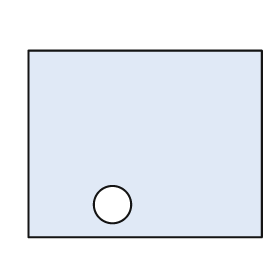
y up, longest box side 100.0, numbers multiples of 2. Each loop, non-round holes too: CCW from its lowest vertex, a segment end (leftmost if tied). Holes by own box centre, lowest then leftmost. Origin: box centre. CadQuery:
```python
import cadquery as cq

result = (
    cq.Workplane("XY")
    .moveTo(-50.0, -40.0)
    .lineTo(50.0, -40.0)
    .lineTo(50.0, 40.0)
    .lineTo(-50.0, 40.0)
    .close()
    .moveTo(-14.0, -26.0)
    .circle(8.0)
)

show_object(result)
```